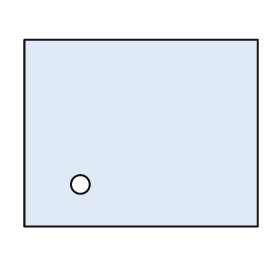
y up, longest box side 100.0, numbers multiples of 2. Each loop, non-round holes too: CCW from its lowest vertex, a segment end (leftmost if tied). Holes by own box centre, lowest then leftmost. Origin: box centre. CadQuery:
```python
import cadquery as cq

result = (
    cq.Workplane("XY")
    .moveTo(-50.0, -40.0)
    .lineTo(50.0, -40.0)
    .lineTo(50.0, 40.0)
    .lineTo(-50.0, 40.0)
    .close()
    .moveTo(-26.0, -22.0)
    .circle(4.0)
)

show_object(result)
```